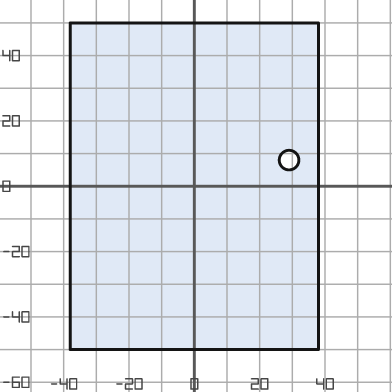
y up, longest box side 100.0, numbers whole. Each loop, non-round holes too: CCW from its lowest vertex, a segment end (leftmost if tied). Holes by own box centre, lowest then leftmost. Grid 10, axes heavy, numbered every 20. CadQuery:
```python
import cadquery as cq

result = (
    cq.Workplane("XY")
    .moveTo(-38.0, -50.0)
    .lineTo(38.0, -50.0)
    .lineTo(38.0, 50.0)
    .lineTo(-38.0, 50.0)
    .close()
    .moveTo(29.0, 8.0)
    .circle(3.0)
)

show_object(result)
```